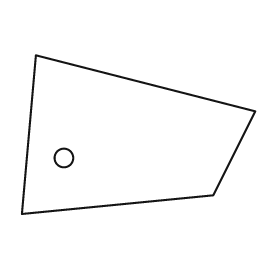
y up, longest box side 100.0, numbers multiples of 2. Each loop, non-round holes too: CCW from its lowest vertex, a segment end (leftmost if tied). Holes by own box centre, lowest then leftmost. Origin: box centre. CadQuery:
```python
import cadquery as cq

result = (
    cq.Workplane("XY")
    .moveTo(-50.0, -34.0)
    .lineTo(32.0, -26.0)
    .lineTo(50.0, 10.0)
    .lineTo(-44.0, 34.0)
    .close()
    .moveTo(-32.0, -10.0)
    .circle(4.0)
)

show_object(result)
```